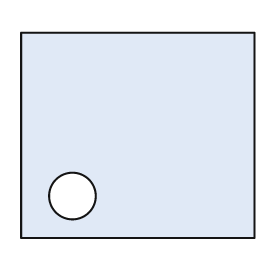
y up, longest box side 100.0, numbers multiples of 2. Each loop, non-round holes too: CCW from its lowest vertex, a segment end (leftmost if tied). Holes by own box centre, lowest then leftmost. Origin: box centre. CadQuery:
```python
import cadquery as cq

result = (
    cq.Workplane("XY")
    .moveTo(-50.0, -44.0)
    .lineTo(50.0, -44.0)
    .lineTo(50.0, 44.0)
    .lineTo(-50.0, 44.0)
    .close()
    .moveTo(-28.0, -26.0)
    .circle(10.0)
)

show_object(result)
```